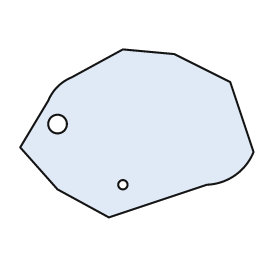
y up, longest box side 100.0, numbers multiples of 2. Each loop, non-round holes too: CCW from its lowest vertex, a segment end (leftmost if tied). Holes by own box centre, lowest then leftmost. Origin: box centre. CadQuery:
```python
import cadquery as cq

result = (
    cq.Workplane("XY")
    .moveTo(-12.0, -36.0)
    .lineTo(30.0, -22.0)
    .threePointArc((42.0, -18.0), (50.0, -8.0))
    .lineTo(40.0, 22.0)
    .lineTo(16.0, 34.0)
    .lineTo(-6.0, 36.0)
    .lineTo(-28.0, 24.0)
    .threePointArc((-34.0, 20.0), (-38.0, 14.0))
    .lineTo(-50.0, -6.0)
    .lineTo(-34.0, -24.0)
    .close()
    .moveTo(-6.0, -22.0)
    .circle(2.0)
    .moveTo(-34.0, 4.0)
    .circle(4.0)
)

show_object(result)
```